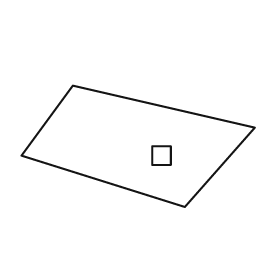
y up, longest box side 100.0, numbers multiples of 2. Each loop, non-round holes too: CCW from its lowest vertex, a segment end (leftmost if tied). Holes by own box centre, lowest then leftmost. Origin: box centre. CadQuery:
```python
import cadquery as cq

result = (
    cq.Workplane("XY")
    .moveTo(20.0, -26.0)
    .lineTo(50.0, 8.0)
    .lineTo(-28.0, 26.0)
    .lineTo(-50.0, -4.0)
    .close()
    .moveTo(6.0, -8.0)
    .lineTo(14.0, -8.0)
    .lineTo(14.0, 0.0)
    .lineTo(6.0, 0.0)
    .close()
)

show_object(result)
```